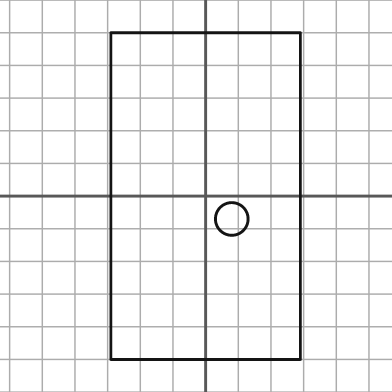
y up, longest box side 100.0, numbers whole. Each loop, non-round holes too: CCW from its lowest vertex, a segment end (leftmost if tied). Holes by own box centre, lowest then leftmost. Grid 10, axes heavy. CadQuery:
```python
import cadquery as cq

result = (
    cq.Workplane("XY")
    .moveTo(-29.0, -50.0)
    .lineTo(29.0, -50.0)
    .lineTo(29.0, 50.0)
    .lineTo(-29.0, 50.0)
    .close()
    .moveTo(8.0, -7.0)
    .circle(5.0)
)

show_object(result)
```